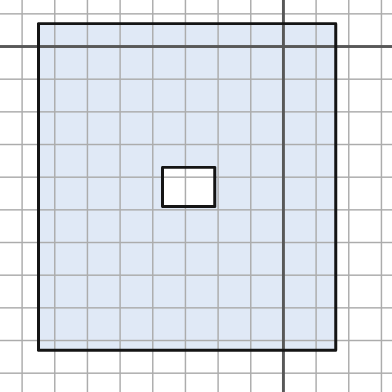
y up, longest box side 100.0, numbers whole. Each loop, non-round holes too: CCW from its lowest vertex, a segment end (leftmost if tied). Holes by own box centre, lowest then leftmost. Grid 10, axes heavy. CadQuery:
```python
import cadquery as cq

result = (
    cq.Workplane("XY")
    .moveTo(-75.0, -93.0)
    .lineTo(16.0, -93.0)
    .lineTo(16.0, 7.0)
    .lineTo(-75.0, 7.0)
    .close()
    .moveTo(-37.0, -49.0)
    .lineTo(-21.0, -49.0)
    .lineTo(-21.0, -37.0)
    .lineTo(-37.0, -37.0)
    .close()
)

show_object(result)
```